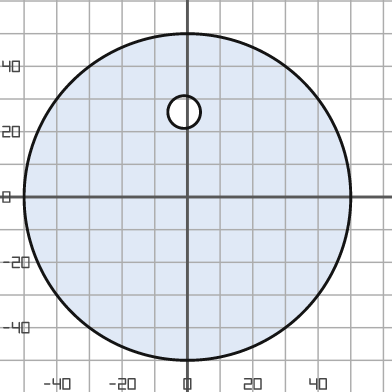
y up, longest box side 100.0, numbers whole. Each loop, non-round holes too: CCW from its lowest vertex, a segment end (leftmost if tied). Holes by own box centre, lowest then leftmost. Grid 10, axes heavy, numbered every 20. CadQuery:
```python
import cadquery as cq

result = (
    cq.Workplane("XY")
    .moveTo(0.0, 0.0)
    .circle(50.0)
    .moveTo(-1.0, 26.0)
    .circle(5.0)
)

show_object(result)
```